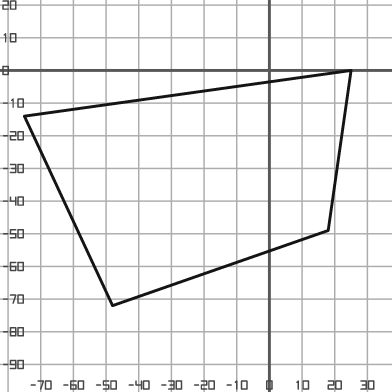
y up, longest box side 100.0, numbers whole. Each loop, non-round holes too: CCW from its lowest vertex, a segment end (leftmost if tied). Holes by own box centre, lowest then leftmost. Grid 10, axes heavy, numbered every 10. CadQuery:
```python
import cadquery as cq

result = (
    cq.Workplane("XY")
    .moveTo(-48.0, -72.0)
    .lineTo(18.0, -49.0)
    .lineTo(25.0, 0.0)
    .lineTo(-75.0, -14.0)
    .close()
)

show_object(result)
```